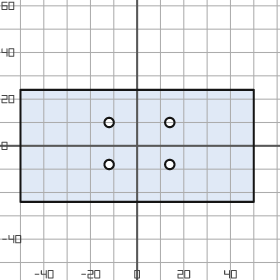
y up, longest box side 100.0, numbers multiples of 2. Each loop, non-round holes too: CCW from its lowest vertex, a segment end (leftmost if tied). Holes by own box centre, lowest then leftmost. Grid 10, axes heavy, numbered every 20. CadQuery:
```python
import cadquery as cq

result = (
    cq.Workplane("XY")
    .moveTo(-50.0, -24.0)
    .lineTo(50.0, -24.0)
    .lineTo(50.0, 24.0)
    .lineTo(-50.0, 24.0)
    .close()
    .moveTo(-12.0, -8.0)
    .circle(2.0)
    .moveTo(14.0, -8.0)
    .circle(2.0)
    .moveTo(-12.0, 10.0)
    .circle(2.0)
    .moveTo(14.0, 10.0)
    .circle(2.0)
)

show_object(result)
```